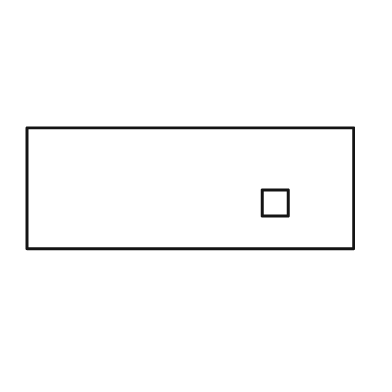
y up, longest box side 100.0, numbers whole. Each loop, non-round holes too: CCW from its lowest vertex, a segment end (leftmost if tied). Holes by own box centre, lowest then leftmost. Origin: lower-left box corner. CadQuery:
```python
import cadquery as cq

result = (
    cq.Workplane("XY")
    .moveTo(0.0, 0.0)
    .lineTo(100.0, 0.0)
    .lineTo(100.0, 37.0)
    .lineTo(0.0, 37.0)
    .close()
    .moveTo(72.0, 10.0)
    .lineTo(80.0, 10.0)
    .lineTo(80.0, 18.0)
    .lineTo(72.0, 18.0)
    .close()
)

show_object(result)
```